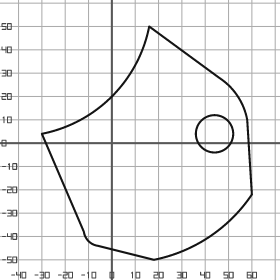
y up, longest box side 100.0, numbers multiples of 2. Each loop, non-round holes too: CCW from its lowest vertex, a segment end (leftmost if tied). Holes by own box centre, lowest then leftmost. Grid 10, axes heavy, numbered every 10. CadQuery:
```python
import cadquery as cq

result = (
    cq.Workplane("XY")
    .moveTo(18.0, -50.0)
    .threePointArc((42.0, -40.0), (60.0, -22.0))
    .lineTo(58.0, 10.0)
    .threePointArc((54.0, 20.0), (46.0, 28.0))
    .lineTo(16.0, 50.0)
    .threePointArc((0.0, 20.0), (-30.0, 4.0))
    .lineTo(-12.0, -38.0)
    .threePointArc((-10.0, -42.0), (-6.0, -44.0))
    .close()
    .moveTo(44.0, 4.0)
    .circle(8.0)
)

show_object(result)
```